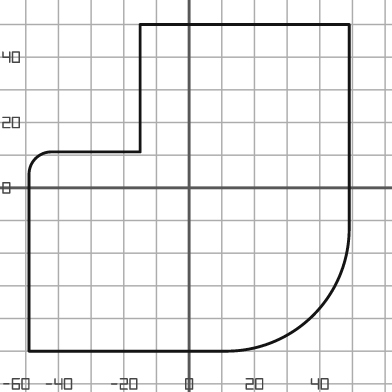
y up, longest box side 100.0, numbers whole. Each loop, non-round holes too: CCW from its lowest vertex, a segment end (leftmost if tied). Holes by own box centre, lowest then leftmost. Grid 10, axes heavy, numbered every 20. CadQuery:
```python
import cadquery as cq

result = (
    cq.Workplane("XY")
    .moveTo(-49.0, -50.0)
    .lineTo(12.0, -50.0)
    .threePointArc((38.0, -39.0), (49.0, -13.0))
    .lineTo(49.0, 50.0)
    .lineTo(-15.0, 50.0)
    .lineTo(-15.0, 11.0)
    .lineTo(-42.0, 11.0)
    .threePointArc((-47.0, 9.0), (-49.0, 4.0))
    .close()
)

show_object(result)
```